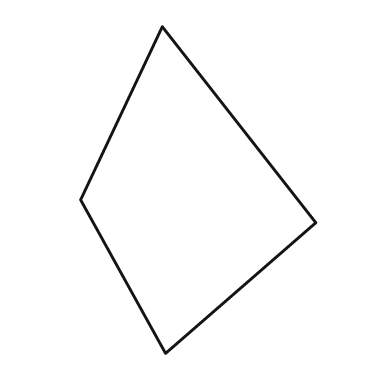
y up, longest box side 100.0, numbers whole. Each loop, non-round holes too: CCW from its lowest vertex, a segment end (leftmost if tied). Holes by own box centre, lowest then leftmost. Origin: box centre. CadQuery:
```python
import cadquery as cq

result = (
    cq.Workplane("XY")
    .moveTo(-10.0, -50.0)
    .lineTo(36.0, -10.0)
    .lineTo(-11.0, 50.0)
    .lineTo(-36.0, -3.0)
    .close()
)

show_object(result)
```